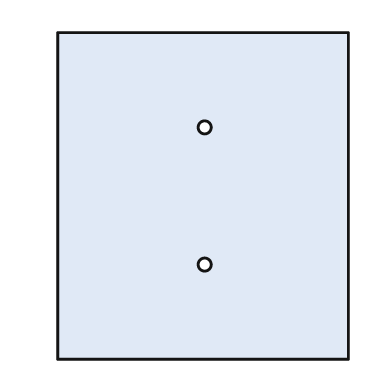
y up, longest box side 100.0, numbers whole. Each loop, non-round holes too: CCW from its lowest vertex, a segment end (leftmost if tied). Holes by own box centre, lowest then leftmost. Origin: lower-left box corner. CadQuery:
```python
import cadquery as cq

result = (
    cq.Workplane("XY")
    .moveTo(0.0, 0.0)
    .lineTo(89.0, 0.0)
    .lineTo(89.0, 100.0)
    .lineTo(0.0, 100.0)
    .close()
    .moveTo(45.0, 29.0)
    .circle(2.0)
    .moveTo(45.0, 71.0)
    .circle(2.0)
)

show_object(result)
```